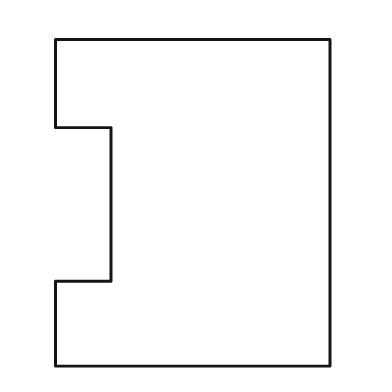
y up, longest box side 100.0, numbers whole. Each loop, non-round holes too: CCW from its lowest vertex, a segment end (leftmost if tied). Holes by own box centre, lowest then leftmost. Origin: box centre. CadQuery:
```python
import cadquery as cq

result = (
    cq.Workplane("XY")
    .moveTo(-42.0, -50.0)
    .lineTo(42.0, -50.0)
    .lineTo(42.0, 50.0)
    .lineTo(-42.0, 50.0)
    .lineTo(-42.0, 23.0)
    .lineTo(-25.0, 23.0)
    .lineTo(-25.0, -24.0)
    .lineTo(-42.0, -24.0)
    .close()
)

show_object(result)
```